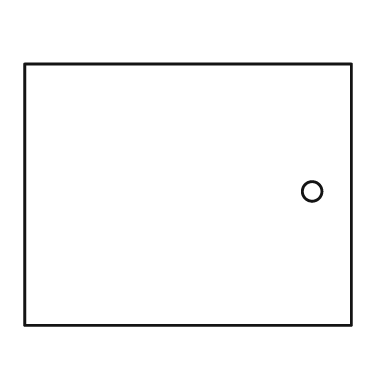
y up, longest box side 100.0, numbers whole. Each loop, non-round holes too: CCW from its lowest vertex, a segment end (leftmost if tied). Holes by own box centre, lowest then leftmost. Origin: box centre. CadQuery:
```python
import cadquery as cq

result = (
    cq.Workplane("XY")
    .moveTo(-50.0, -40.0)
    .lineTo(50.0, -40.0)
    .lineTo(50.0, 40.0)
    .lineTo(-50.0, 40.0)
    .close()
    .moveTo(38.0, 1.0)
    .circle(3.0)
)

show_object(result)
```